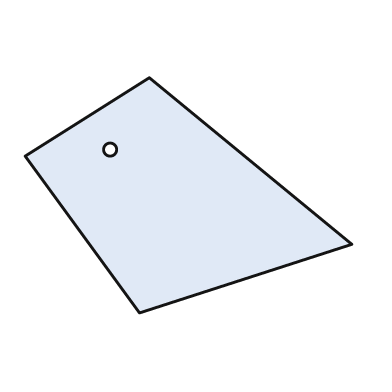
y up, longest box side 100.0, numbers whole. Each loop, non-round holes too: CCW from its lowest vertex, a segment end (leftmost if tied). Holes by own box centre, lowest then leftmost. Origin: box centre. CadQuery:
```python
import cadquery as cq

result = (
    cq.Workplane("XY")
    .moveTo(-15.0, -36.0)
    .lineTo(50.0, -15.0)
    .lineTo(-12.0, 36.0)
    .lineTo(-50.0, 12.0)
    .close()
    .moveTo(-24.0, 14.0)
    .circle(2.0)
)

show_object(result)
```